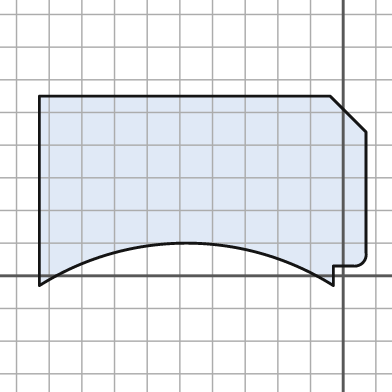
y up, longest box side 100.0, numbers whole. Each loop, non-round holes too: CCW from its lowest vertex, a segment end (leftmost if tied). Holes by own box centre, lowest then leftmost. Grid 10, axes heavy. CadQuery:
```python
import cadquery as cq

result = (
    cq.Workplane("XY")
    .moveTo(-93.0, -3.0)
    .threePointArc((-48.0, 10.0), (-3.0, -3.0))
    .lineTo(-3.0, 3.0)
    .lineTo(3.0, 3.0)
    .threePointArc((6.0, 4.0), (7.0, 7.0))
    .lineTo(7.0, 44.0)
    .lineTo(-4.0, 55.0)
    .lineTo(-93.0, 55.0)
    .close()
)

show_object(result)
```